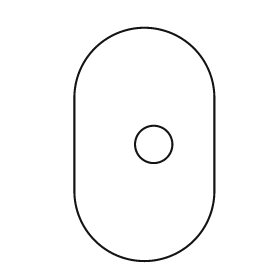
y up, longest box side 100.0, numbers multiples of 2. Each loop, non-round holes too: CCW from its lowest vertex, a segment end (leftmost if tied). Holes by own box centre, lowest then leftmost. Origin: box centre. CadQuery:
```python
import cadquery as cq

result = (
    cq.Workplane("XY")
    .moveTo(-30.0, -20.0)
    .threePointArc((0.0, -50.0), (30.0, -20.0))
    .lineTo(30.0, 20.0)
    .threePointArc((0.0, 50.0), (-30.0, 20.0))
    .close()
    .moveTo(4.0, 0.0)
    .circle(8.0)
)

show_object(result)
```